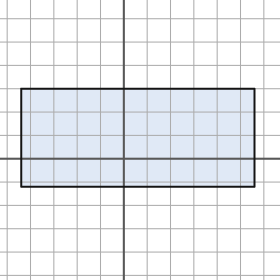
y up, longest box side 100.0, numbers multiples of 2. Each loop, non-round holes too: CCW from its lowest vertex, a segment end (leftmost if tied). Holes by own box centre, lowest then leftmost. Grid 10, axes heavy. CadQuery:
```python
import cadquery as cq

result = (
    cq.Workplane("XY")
    .moveTo(-44.0, -12.0)
    .lineTo(56.0, -12.0)
    .lineTo(56.0, 30.0)
    .lineTo(-44.0, 30.0)
    .close()
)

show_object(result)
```